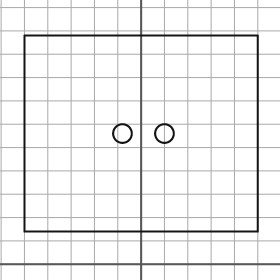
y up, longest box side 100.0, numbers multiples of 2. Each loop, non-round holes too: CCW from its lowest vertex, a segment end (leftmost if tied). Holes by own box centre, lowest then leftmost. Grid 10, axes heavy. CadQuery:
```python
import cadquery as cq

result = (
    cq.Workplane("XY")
    .moveTo(-50.0, 14.0)
    .lineTo(50.0, 14.0)
    .lineTo(50.0, 98.0)
    .lineTo(-50.0, 98.0)
    .close()
    .moveTo(-8.0, 56.0)
    .circle(4.0)
    .moveTo(10.0, 56.0)
    .circle(4.0)
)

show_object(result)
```